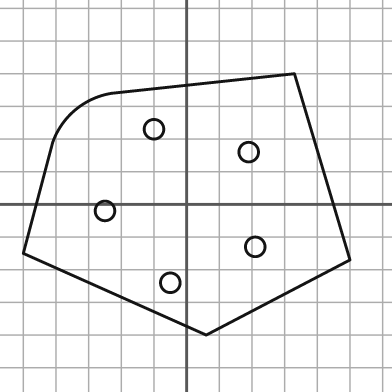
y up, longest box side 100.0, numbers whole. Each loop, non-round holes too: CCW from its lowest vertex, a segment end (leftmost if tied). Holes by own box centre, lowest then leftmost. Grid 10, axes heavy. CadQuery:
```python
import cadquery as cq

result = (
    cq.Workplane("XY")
    .moveTo(6.0, -40.0)
    .lineTo(50.0, -17.0)
    .lineTo(33.0, 40.0)
    .lineTo(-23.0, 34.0)
    .threePointArc((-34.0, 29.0), (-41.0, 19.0))
    .lineTo(-50.0, -15.0)
    .close()
    .moveTo(-5.0, -24.0)
    .circle(3.0)
    .moveTo(21.0, -13.0)
    .circle(3.0)
    .moveTo(-25.0, -2.0)
    .circle(3.0)
    .moveTo(19.0, 16.0)
    .circle(3.0)
    .moveTo(-10.0, 23.0)
    .circle(3.0)
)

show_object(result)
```